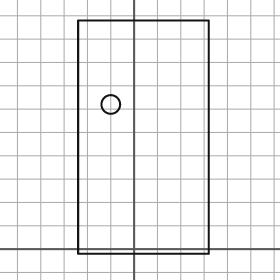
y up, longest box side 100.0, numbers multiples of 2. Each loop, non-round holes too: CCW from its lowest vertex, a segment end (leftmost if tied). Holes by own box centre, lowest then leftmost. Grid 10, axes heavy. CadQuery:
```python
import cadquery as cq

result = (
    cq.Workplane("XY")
    .moveTo(-24.0, -2.0)
    .lineTo(32.0, -2.0)
    .lineTo(32.0, 98.0)
    .lineTo(-24.0, 98.0)
    .close()
    .moveTo(-10.0, 62.0)
    .circle(4.0)
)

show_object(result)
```